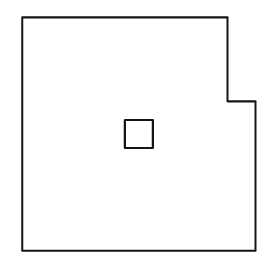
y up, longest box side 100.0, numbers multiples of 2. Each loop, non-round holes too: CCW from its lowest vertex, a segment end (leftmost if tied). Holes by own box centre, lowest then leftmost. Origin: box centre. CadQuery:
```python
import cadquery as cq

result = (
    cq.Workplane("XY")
    .moveTo(-50.0, -50.0)
    .lineTo(50.0, -50.0)
    .lineTo(50.0, 14.0)
    .lineTo(38.0, 14.0)
    .lineTo(38.0, 50.0)
    .lineTo(-50.0, 50.0)
    .close()
    .moveTo(-6.0, -6.0)
    .lineTo(6.0, -6.0)
    .lineTo(6.0, 6.0)
    .lineTo(-6.0, 6.0)
    .close()
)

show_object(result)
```